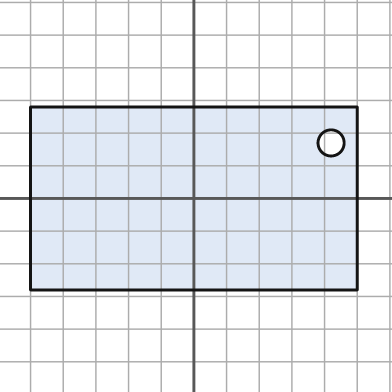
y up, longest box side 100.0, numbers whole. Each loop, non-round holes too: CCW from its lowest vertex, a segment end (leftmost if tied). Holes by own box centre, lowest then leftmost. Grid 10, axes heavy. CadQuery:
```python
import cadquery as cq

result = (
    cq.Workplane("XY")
    .moveTo(-50.0, -28.0)
    .lineTo(50.0, -28.0)
    .lineTo(50.0, 28.0)
    .lineTo(-50.0, 28.0)
    .close()
    .moveTo(42.0, 17.0)
    .circle(4.0)
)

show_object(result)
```